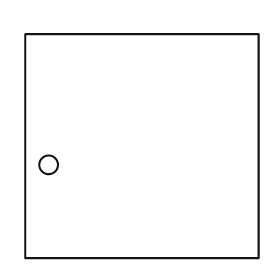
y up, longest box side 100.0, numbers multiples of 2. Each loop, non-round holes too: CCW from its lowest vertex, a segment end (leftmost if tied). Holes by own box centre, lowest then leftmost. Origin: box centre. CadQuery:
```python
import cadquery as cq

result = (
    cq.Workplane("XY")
    .moveTo(-50.0, -48.0)
    .lineTo(50.0, -48.0)
    .lineTo(50.0, 48.0)
    .lineTo(-50.0, 48.0)
    .close()
    .moveTo(-40.0, -8.0)
    .circle(4.0)
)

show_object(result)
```